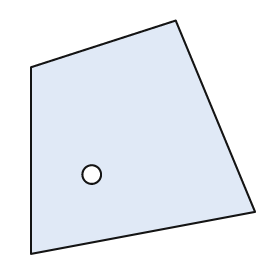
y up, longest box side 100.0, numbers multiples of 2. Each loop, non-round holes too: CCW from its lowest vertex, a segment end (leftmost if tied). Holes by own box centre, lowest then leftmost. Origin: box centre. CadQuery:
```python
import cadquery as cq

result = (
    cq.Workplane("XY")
    .moveTo(-48.0, -50.0)
    .lineTo(48.0, -32.0)
    .lineTo(14.0, 50.0)
    .lineTo(-48.0, 30.0)
    .close()
    .moveTo(-22.0, -16.0)
    .circle(4.0)
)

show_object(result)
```